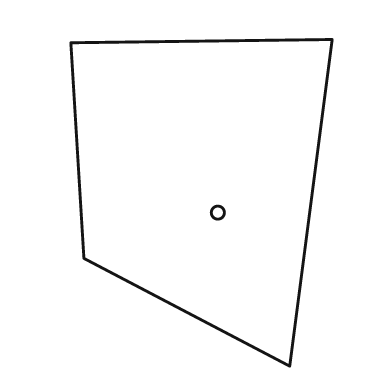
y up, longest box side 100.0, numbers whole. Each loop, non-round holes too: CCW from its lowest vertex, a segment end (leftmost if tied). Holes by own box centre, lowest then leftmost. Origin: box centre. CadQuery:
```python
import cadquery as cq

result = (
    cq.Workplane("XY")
    .moveTo(27.0, -50.0)
    .lineTo(40.0, 50.0)
    .lineTo(-40.0, 49.0)
    .lineTo(-36.0, -17.0)
    .close()
    .moveTo(5.0, -3.0)
    .circle(2.0)
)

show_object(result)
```